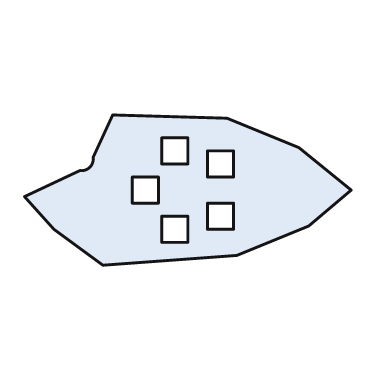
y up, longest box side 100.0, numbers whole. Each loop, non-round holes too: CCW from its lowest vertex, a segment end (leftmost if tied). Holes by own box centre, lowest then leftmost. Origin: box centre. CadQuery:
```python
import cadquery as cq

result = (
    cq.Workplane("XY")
    .moveTo(-26.0, -23.0)
    .lineTo(15.0, -20.0)
    .lineTo(37.0, -11.0)
    .lineTo(50.0, 0.0)
    .lineTo(34.0, 13.0)
    .lineTo(12.0, 22.0)
    .lineTo(-23.0, 23.0)
    .lineTo(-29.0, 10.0)
    .threePointArc((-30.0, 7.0), (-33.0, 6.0))
    .lineTo(-50.0, -2.0)
    .lineTo(-41.0, -12.0)
    .close()
    .moveTo(-8.0, -16.0)
    .lineTo(0.0, -16.0)
    .lineTo(0.0, -8.0)
    .lineTo(-8.0, -8.0)
    .close()
    .moveTo(6.0, -12.0)
    .lineTo(14.0, -12.0)
    .lineTo(14.0, -4.0)
    .lineTo(6.0, -4.0)
    .close()
    .moveTo(-17.0, -4.0)
    .lineTo(-9.0, -4.0)
    .lineTo(-9.0, 4.0)
    .lineTo(-17.0, 4.0)
    .close()
    .moveTo(6.0, 4.0)
    .lineTo(14.0, 4.0)
    .lineTo(14.0, 12.0)
    .lineTo(6.0, 12.0)
    .close()
    .moveTo(-8.0, 8.0)
    .lineTo(0.0, 8.0)
    .lineTo(0.0, 16.0)
    .lineTo(-8.0, 16.0)
    .close()
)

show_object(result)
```